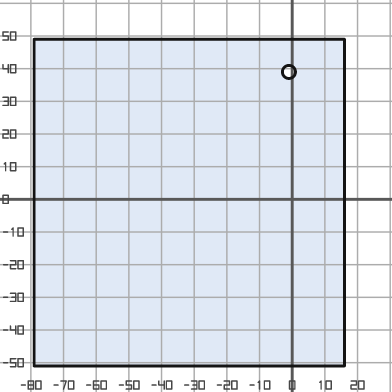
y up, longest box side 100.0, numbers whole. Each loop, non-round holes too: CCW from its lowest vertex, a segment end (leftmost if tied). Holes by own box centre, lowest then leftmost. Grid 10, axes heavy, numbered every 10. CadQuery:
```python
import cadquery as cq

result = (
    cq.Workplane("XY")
    .moveTo(-79.0, -51.0)
    .lineTo(16.0, -51.0)
    .lineTo(16.0, 49.0)
    .lineTo(-79.0, 49.0)
    .close()
    .moveTo(-1.0, 39.0)
    .circle(2.0)
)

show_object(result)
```